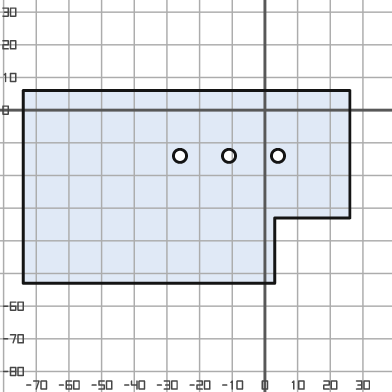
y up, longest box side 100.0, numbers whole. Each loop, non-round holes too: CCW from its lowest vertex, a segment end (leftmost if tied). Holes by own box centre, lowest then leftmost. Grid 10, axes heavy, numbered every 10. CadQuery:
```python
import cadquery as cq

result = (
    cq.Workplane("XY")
    .moveTo(-74.0, -53.0)
    .lineTo(3.0, -53.0)
    .lineTo(3.0, -33.0)
    .lineTo(26.0, -33.0)
    .lineTo(26.0, 6.0)
    .lineTo(-74.0, 6.0)
    .close()
    .moveTo(-26.0, -14.0)
    .circle(2.0)
    .moveTo(-11.0, -14.0)
    .circle(2.0)
    .moveTo(4.0, -14.0)
    .circle(2.0)
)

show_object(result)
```